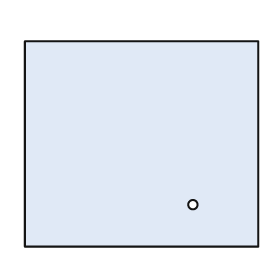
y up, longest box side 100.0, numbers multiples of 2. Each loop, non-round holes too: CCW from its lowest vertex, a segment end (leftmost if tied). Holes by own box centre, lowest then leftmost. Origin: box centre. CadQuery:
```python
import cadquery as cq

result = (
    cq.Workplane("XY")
    .moveTo(-50.0, -44.0)
    .lineTo(50.0, -44.0)
    .lineTo(50.0, 44.0)
    .lineTo(-50.0, 44.0)
    .close()
    .moveTo(22.0, -26.0)
    .circle(2.0)
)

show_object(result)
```